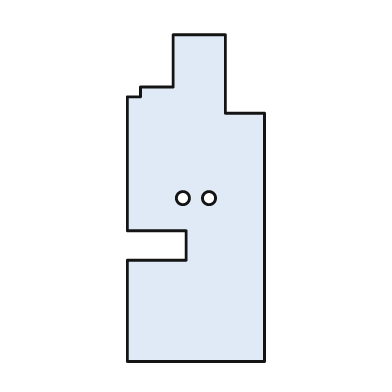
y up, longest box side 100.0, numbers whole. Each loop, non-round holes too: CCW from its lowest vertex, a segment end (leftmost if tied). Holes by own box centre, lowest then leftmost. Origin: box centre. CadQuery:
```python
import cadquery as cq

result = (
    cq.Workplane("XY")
    .moveTo(-21.0, -50.0)
    .lineTo(21.0, -50.0)
    .lineTo(21.0, 26.0)
    .lineTo(9.0, 26.0)
    .lineTo(9.0, 50.0)
    .lineTo(-7.0, 50.0)
    .lineTo(-7.0, 34.0)
    .lineTo(-17.0, 34.0)
    .lineTo(-17.0, 31.0)
    .lineTo(-21.0, 31.0)
    .lineTo(-21.0, -10.0)
    .lineTo(-3.0, -10.0)
    .lineTo(-3.0, -19.0)
    .lineTo(-21.0, -19.0)
    .close()
    .moveTo(-4.0, 0.0)
    .circle(2.0)
    .moveTo(4.0, 0.0)
    .circle(2.0)
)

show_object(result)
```